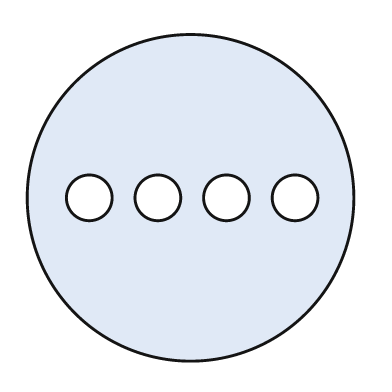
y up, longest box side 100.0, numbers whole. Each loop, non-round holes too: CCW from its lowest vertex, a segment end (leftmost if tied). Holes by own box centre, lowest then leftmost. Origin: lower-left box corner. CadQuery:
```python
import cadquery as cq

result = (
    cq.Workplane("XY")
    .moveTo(50.0, 50.0)
    .circle(50.0)
    .moveTo(19.0, 50.0)
    .circle(7.0)
    .moveTo(40.0, 50.0)
    .circle(7.0)
    .moveTo(61.0, 50.0)
    .circle(7.0)
    .moveTo(82.0, 50.0)
    .circle(7.0)
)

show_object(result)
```